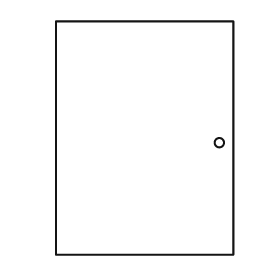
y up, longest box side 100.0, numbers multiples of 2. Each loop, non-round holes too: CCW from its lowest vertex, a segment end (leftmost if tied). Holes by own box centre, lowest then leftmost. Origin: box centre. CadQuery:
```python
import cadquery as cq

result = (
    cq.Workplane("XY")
    .moveTo(-38.0, -50.0)
    .lineTo(38.0, -50.0)
    .lineTo(38.0, 50.0)
    .lineTo(-38.0, 50.0)
    .close()
    .moveTo(32.0, -2.0)
    .circle(2.0)
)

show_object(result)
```